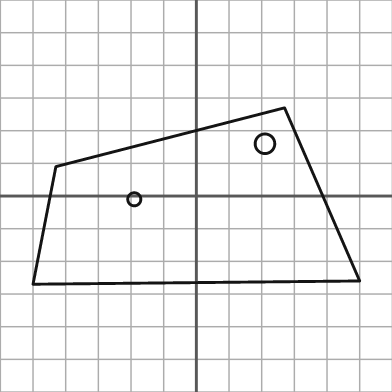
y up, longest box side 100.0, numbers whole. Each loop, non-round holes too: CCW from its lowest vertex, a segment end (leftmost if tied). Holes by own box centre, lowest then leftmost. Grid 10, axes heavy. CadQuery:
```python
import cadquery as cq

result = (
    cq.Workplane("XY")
    .moveTo(-50.0, -27.0)
    .lineTo(50.0, -26.0)
    .lineTo(27.0, 27.0)
    .lineTo(-43.0, 9.0)
    .close()
    .moveTo(-19.0, -1.0)
    .circle(2.0)
    .moveTo(21.0, 16.0)
    .circle(3.0)
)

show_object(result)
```